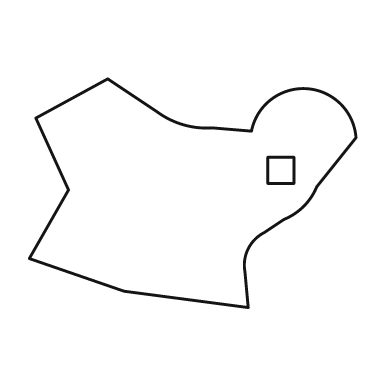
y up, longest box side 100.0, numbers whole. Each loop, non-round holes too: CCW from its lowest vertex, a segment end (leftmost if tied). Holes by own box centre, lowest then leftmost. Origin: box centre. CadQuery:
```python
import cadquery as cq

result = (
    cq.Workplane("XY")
    .moveTo(17.0, -35.0)
    .lineTo(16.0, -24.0)
    .threePointArc((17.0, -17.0), (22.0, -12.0))
    .lineTo(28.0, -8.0)
    .threePointArc((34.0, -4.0), (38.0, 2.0))
    .lineTo(50.0, 17.0)
    .threePointArc((35.0, 32.0), (18.0, 19.0))
    .lineTo(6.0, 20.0)
    .threePointArc((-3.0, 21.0), (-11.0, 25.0))
    .lineTo(-26.0, 35.0)
    .lineTo(-48.0, 23.0)
    .lineTo(-38.0, 1.0)
    .lineTo(-50.0, -20.0)
    .lineTo(-21.0, -30.0)
    .close()
    .moveTo(23.0, 3.0)
    .lineTo(31.0, 3.0)
    .lineTo(31.0, 11.0)
    .lineTo(23.0, 11.0)
    .close()
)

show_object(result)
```